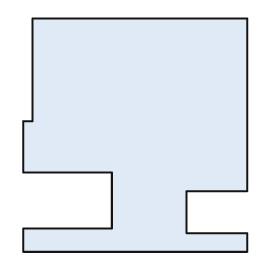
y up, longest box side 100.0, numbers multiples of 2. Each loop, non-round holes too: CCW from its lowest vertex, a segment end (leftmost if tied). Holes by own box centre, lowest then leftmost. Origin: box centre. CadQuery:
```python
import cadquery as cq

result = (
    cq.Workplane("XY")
    .moveTo(-48.0, -50.0)
    .lineTo(48.0, -50.0)
    .lineTo(48.0, -42.0)
    .lineTo(22.0, -42.0)
    .lineTo(22.0, -24.0)
    .lineTo(48.0, -24.0)
    .lineTo(48.0, 50.0)
    .lineTo(-44.0, 50.0)
    .lineTo(-44.0, 6.0)
    .lineTo(-48.0, 6.0)
    .lineTo(-48.0, -16.0)
    .lineTo(-10.0, -16.0)
    .lineTo(-10.0, -40.0)
    .lineTo(-48.0, -40.0)
    .close()
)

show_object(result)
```